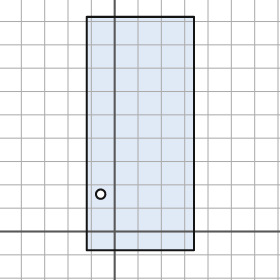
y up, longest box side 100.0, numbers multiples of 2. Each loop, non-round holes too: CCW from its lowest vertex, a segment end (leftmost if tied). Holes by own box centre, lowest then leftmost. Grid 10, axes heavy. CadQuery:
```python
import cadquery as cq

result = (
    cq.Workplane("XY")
    .moveTo(-12.0, -8.0)
    .lineTo(34.0, -8.0)
    .lineTo(34.0, 92.0)
    .lineTo(-12.0, 92.0)
    .close()
    .moveTo(-6.0, 16.0)
    .circle(2.0)
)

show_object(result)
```